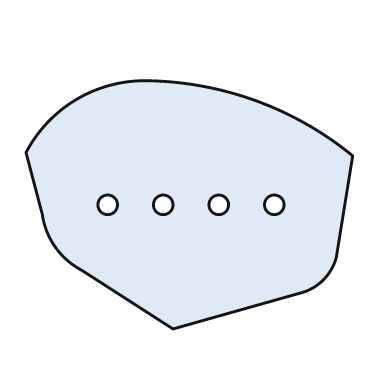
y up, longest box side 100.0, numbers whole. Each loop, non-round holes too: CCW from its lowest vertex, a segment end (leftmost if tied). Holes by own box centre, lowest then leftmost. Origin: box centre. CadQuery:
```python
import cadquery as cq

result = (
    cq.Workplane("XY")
    .moveTo(-5.0, -38.0)
    .lineTo(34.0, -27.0)
    .threePointArc((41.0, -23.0), (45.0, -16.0))
    .lineTo(50.0, 15.0)
    .threePointArc((20.0, 32.0), (-14.0, 38.0))
    .threePointArc((-35.0, 32.0), (-50.0, 16.0))
    .lineTo(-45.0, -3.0)
    .threePointArc((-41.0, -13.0), (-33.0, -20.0))
    .close()
    .moveTo(-25.0, 0.0)
    .circle(3.0)
    .moveTo(-8.0, 0.0)
    .circle(3.0)
    .moveTo(9.0, 0.0)
    .circle(3.0)
    .moveTo(26.0, 0.0)
    .circle(3.0)
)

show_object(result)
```